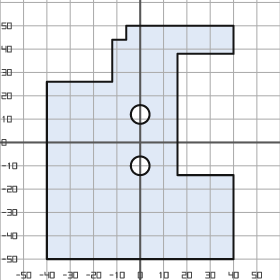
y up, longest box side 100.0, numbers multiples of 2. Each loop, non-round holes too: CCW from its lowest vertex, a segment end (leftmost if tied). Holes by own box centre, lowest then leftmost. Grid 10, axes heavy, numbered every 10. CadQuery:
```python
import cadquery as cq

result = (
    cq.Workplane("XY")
    .moveTo(-40.0, -50.0)
    .lineTo(40.0, -50.0)
    .lineTo(40.0, -14.0)
    .lineTo(16.0, -14.0)
    .lineTo(16.0, 38.0)
    .lineTo(40.0, 38.0)
    .lineTo(40.0, 50.0)
    .lineTo(-6.0, 50.0)
    .lineTo(-6.0, 44.0)
    .lineTo(-12.0, 44.0)
    .lineTo(-12.0, 26.0)
    .lineTo(-40.0, 26.0)
    .close()
    .moveTo(0.0, -10.0)
    .circle(4.0)
    .moveTo(0.0, 12.0)
    .circle(4.0)
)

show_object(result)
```